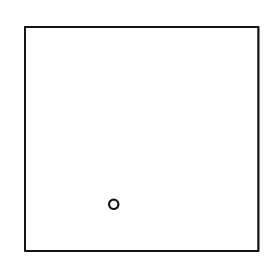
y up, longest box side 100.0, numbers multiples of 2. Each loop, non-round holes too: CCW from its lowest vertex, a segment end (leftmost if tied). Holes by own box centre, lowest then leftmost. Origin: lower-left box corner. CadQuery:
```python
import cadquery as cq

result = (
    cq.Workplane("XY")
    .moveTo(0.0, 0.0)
    .lineTo(100.0, 0.0)
    .lineTo(100.0, 96.0)
    .lineTo(0.0, 96.0)
    .close()
    .moveTo(38.0, 20.0)
    .circle(2.0)
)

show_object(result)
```